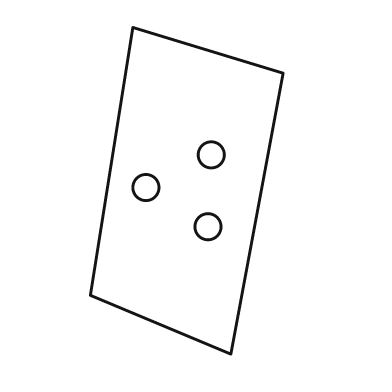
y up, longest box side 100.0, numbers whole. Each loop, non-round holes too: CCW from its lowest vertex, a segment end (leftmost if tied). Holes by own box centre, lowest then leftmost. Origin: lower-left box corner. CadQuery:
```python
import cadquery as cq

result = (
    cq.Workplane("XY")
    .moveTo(43.0, 0.0)
    .lineTo(59.0, 86.0)
    .lineTo(13.0, 100.0)
    .lineTo(0.0, 18.0)
    .close()
    .moveTo(36.0, 39.0)
    .circle(4.0)
    .moveTo(17.0, 51.0)
    .circle(4.0)
    .moveTo(37.0, 61.0)
    .circle(4.0)
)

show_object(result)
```